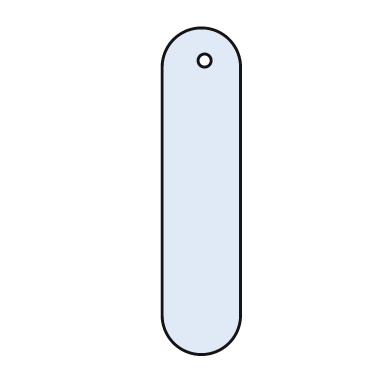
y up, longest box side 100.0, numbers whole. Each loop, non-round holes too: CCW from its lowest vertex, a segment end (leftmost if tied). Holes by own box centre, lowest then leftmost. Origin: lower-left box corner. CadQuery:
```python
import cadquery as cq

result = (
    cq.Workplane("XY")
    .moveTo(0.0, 12.0)
    .threePointArc((12.0, 0.0), (24.0, 12.0))
    .lineTo(24.0, 88.0)
    .threePointArc((12.0, 100.0), (0.0, 88.0))
    .close()
    .moveTo(13.0, 90.0)
    .circle(2.0)
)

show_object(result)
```